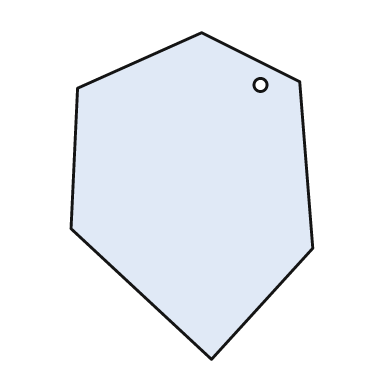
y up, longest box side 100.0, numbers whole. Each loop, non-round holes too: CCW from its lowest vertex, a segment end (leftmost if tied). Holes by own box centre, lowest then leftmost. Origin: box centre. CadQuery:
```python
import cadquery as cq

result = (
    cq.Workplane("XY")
    .moveTo(6.0, -50.0)
    .lineTo(37.0, -16.0)
    .lineTo(33.0, 35.0)
    .lineTo(3.0, 50.0)
    .lineTo(-35.0, 33.0)
    .lineTo(-37.0, -10.0)
    .close()
    .moveTo(21.0, 34.0)
    .circle(2.0)
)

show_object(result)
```